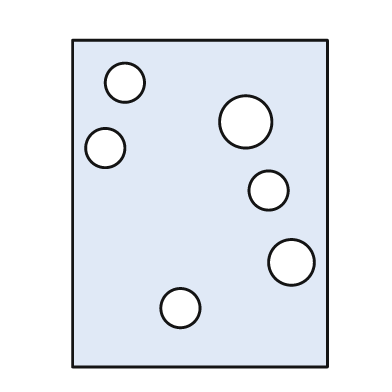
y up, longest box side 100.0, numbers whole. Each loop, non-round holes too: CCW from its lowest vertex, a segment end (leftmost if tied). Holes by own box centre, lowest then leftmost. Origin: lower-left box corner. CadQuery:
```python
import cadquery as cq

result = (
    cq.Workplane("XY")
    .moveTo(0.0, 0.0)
    .lineTo(78.0, 0.0)
    .lineTo(78.0, 100.0)
    .lineTo(0.0, 100.0)
    .close()
    .moveTo(33.0, 18.0)
    .circle(6.0)
    .moveTo(67.0, 32.0)
    .circle(7.0)
    .moveTo(60.0, 54.0)
    .circle(6.0)
    .moveTo(10.0, 67.0)
    .circle(6.0)
    .moveTo(53.0, 75.0)
    .circle(8.0)
    .moveTo(16.0, 87.0)
    .circle(6.0)
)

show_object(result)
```